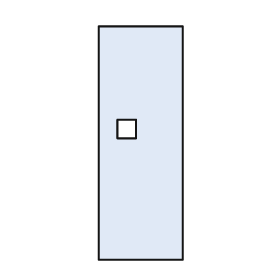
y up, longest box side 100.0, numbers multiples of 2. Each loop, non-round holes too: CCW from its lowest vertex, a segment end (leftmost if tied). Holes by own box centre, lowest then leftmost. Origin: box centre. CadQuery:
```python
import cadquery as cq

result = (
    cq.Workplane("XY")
    .moveTo(-18.0, -50.0)
    .lineTo(18.0, -50.0)
    .lineTo(18.0, 50.0)
    .lineTo(-18.0, 50.0)
    .close()
    .moveTo(-10.0, 2.0)
    .lineTo(-2.0, 2.0)
    .lineTo(-2.0, 10.0)
    .lineTo(-10.0, 10.0)
    .close()
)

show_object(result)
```